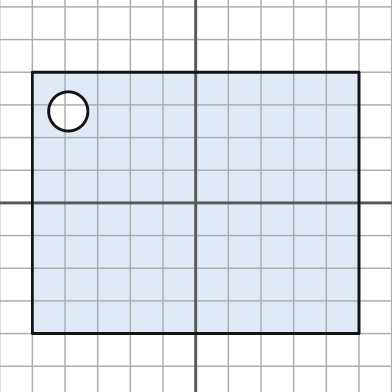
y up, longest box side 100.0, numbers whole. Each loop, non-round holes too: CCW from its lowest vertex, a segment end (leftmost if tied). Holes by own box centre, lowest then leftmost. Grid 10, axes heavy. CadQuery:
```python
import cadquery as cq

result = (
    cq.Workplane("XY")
    .moveTo(-50.0, -40.0)
    .lineTo(50.0, -40.0)
    .lineTo(50.0, 40.0)
    .lineTo(-50.0, 40.0)
    .close()
    .moveTo(-39.0, 28.0)
    .circle(6.0)
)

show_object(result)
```